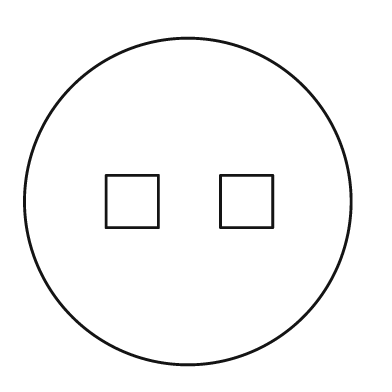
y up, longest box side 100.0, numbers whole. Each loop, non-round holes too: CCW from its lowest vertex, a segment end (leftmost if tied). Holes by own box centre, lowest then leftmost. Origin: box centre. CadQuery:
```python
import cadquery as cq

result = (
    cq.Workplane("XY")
    .moveTo(0.0, 0.0)
    .circle(50.0)
    .moveTo(-25.0, -8.0)
    .lineTo(-9.0, -8.0)
    .lineTo(-9.0, 8.0)
    .lineTo(-25.0, 8.0)
    .close()
    .moveTo(10.0, -8.0)
    .lineTo(26.0, -8.0)
    .lineTo(26.0, 8.0)
    .lineTo(10.0, 8.0)
    .close()
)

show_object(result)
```